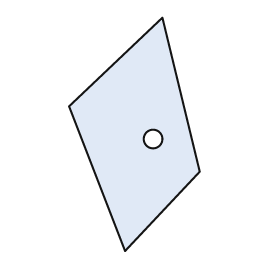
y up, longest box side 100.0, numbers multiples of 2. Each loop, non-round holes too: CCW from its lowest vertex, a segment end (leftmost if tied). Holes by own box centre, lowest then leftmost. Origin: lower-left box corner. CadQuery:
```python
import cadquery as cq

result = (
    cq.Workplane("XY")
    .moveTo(24.0, 0.0)
    .lineTo(56.0, 34.0)
    .lineTo(40.0, 100.0)
    .lineTo(0.0, 62.0)
    .close()
    .moveTo(36.0, 48.0)
    .circle(4.0)
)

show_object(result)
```